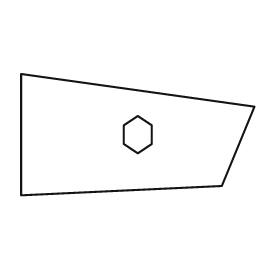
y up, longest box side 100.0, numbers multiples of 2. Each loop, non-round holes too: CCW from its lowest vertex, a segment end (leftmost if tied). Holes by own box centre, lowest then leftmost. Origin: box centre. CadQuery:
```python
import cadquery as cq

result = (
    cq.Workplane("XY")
    .moveTo(-50.0, -26.0)
    .lineTo(36.0, -22.0)
    .lineTo(50.0, 12.0)
    .lineTo(-50.0, 26.0)
    .close()
    .moveTo(0.0, -8.0)
    .lineTo(6.0, -4.0)
    .lineTo(6.0, 4.0)
    .lineTo(0.0, 8.0)
    .lineTo(-6.0, 4.0)
    .lineTo(-6.0, -4.0)
    .close()
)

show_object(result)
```